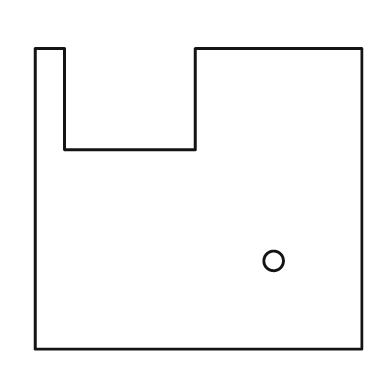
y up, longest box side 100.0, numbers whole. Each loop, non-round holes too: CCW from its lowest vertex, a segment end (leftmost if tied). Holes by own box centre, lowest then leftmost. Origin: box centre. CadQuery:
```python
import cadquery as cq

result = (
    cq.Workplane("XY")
    .moveTo(-50.0, -46.0)
    .lineTo(50.0, -46.0)
    .lineTo(50.0, 46.0)
    .lineTo(-1.0, 46.0)
    .lineTo(-1.0, 15.0)
    .lineTo(-41.0, 15.0)
    .lineTo(-41.0, 46.0)
    .lineTo(-50.0, 46.0)
    .close()
    .moveTo(23.0, -19.0)
    .circle(3.0)
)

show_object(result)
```